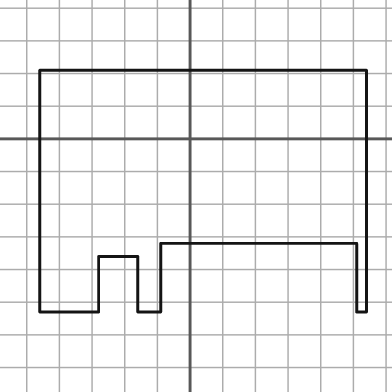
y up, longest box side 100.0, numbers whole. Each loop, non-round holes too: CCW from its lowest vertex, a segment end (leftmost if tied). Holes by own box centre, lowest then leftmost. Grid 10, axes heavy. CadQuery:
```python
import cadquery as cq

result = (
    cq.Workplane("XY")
    .moveTo(-46.0, -53.0)
    .lineTo(-28.0, -53.0)
    .lineTo(-28.0, -36.0)
    .lineTo(-16.0, -36.0)
    .lineTo(-16.0, -53.0)
    .lineTo(-9.0, -53.0)
    .lineTo(-9.0, -32.0)
    .lineTo(51.0, -32.0)
    .lineTo(51.0, -53.0)
    .lineTo(54.0, -53.0)
    .lineTo(54.0, 21.0)
    .lineTo(-46.0, 21.0)
    .close()
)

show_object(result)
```